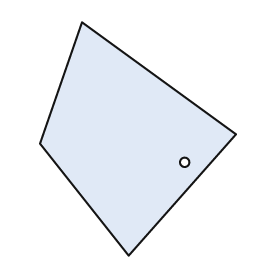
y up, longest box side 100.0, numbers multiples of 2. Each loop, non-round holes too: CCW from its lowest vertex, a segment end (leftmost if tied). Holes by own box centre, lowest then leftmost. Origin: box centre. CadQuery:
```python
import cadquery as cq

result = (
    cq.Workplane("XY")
    .moveTo(-4.0, -50.0)
    .lineTo(42.0, 2.0)
    .lineTo(-24.0, 50.0)
    .lineTo(-42.0, -2.0)
    .close()
    .moveTo(20.0, -10.0)
    .circle(2.0)
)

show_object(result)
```